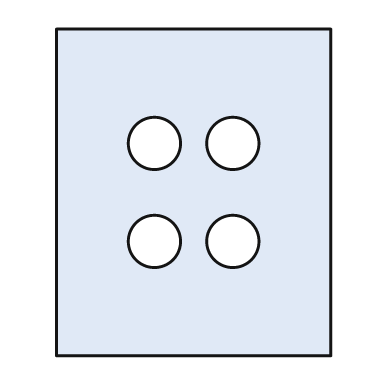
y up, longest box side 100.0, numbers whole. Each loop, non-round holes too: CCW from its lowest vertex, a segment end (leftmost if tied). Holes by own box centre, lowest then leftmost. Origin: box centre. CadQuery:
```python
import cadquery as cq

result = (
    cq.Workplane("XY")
    .moveTo(-42.0, -50.0)
    .lineTo(42.0, -50.0)
    .lineTo(42.0, 50.0)
    .lineTo(-42.0, 50.0)
    .close()
    .moveTo(-12.0, -15.0)
    .circle(8.0)
    .moveTo(12.0, -15.0)
    .circle(8.0)
    .moveTo(-12.0, 15.0)
    .circle(8.0)
    .moveTo(12.0, 15.0)
    .circle(8.0)
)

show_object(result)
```